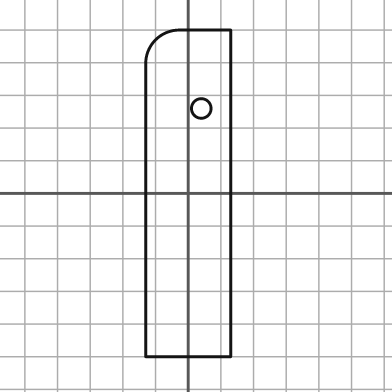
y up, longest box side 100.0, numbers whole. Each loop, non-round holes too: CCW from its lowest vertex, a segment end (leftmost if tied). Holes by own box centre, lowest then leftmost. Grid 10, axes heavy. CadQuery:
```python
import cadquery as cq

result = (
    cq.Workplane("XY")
    .moveTo(-13.0, -50.0)
    .lineTo(13.0, -50.0)
    .lineTo(13.0, 50.0)
    .lineTo(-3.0, 50.0)
    .threePointArc((-10.0, 47.0), (-13.0, 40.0))
    .close()
    .moveTo(4.0, 26.0)
    .circle(3.0)
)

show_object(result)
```